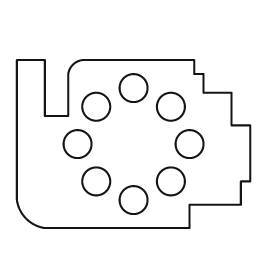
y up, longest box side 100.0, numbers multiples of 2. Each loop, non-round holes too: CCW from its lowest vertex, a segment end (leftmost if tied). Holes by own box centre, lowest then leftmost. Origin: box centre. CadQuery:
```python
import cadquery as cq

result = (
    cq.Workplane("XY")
    .moveTo(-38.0, -36.0)
    .lineTo(24.0, -36.0)
    .lineTo(24.0, -26.0)
    .lineTo(46.0, -26.0)
    .lineTo(46.0, -16.0)
    .lineTo(50.0, -16.0)
    .lineTo(50.0, 8.0)
    .lineTo(42.0, 8.0)
    .lineTo(42.0, 22.0)
    .lineTo(30.0, 22.0)
    .lineTo(30.0, 30.0)
    .lineTo(26.0, 30.0)
    .lineTo(26.0, 36.0)
    .lineTo(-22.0, 36.0)
    .threePointArc((-26.0, 34.0), (-28.0, 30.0))
    .lineTo(-28.0, 12.0)
    .lineTo(-38.0, 12.0)
    .lineTo(-38.0, 36.0)
    .lineTo(-50.0, 36.0)
    .lineTo(-50.0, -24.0)
    .threePointArc((-46.0, -32.0), (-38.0, -36.0))
    .close()
    .moveTo(0.0, -24.0)
    .circle(6.0)
    .moveTo(-16.0, -16.0)
    .circle(6.0)
    .moveTo(16.0, -16.0)
    .circle(6.0)
    .moveTo(-24.0, 0.0)
    .circle(6.0)
    .moveTo(24.0, 0.0)
    .circle(6.0)
    .moveTo(-16.0, 16.0)
    .circle(6.0)
    .moveTo(16.0, 16.0)
    .circle(6.0)
    .moveTo(0.0, 24.0)
    .circle(6.0)
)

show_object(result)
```